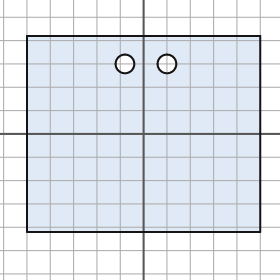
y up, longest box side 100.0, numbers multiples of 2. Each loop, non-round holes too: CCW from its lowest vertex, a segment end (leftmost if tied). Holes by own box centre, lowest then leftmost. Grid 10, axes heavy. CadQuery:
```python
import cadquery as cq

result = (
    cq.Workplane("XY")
    .moveTo(-50.0, -42.0)
    .lineTo(50.0, -42.0)
    .lineTo(50.0, 42.0)
    .lineTo(-50.0, 42.0)
    .close()
    .moveTo(-8.0, 30.0)
    .circle(4.0)
    .moveTo(10.0, 30.0)
    .circle(4.0)
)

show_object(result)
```